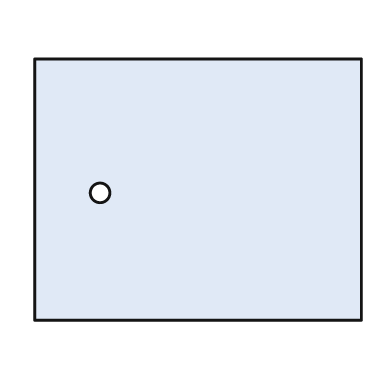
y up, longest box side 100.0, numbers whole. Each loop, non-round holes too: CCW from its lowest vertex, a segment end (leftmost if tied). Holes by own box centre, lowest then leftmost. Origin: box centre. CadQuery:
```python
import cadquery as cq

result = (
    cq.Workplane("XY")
    .moveTo(-50.0, -40.0)
    .lineTo(50.0, -40.0)
    .lineTo(50.0, 40.0)
    .lineTo(-50.0, 40.0)
    .close()
    .moveTo(-30.0, -1.0)
    .circle(3.0)
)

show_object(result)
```